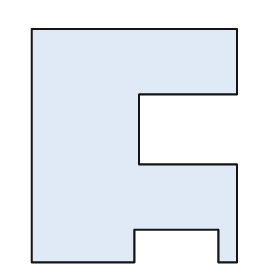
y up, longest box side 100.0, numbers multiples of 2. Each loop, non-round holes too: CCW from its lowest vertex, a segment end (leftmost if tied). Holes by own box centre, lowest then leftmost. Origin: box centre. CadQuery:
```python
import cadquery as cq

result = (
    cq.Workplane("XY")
    .moveTo(-44.0, -50.0)
    .lineTo(0.0, -50.0)
    .lineTo(0.0, -36.0)
    .lineTo(36.0, -36.0)
    .lineTo(36.0, -50.0)
    .lineTo(44.0, -50.0)
    .lineTo(44.0, -8.0)
    .lineTo(2.0, -8.0)
    .lineTo(2.0, 22.0)
    .lineTo(44.0, 22.0)
    .lineTo(44.0, 50.0)
    .lineTo(-44.0, 50.0)
    .close()
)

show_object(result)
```